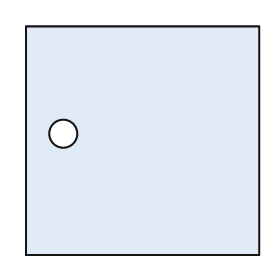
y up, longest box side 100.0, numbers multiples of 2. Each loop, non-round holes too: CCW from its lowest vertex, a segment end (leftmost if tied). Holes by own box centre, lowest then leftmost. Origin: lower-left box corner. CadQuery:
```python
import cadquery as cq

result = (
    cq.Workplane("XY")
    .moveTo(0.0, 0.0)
    .lineTo(100.0, 0.0)
    .lineTo(100.0, 98.0)
    .lineTo(0.0, 98.0)
    .close()
    .moveTo(16.0, 52.0)
    .circle(6.0)
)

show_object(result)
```